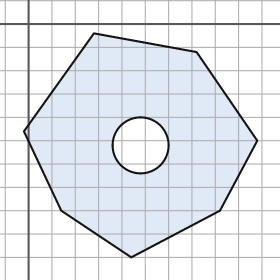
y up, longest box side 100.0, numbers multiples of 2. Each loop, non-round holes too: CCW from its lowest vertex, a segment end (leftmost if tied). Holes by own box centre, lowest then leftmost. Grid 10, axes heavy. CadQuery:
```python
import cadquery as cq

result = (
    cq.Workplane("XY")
    .moveTo(44.0, -100.0)
    .lineTo(82.0, -80.0)
    .lineTo(98.0, -50.0)
    .lineTo(72.0, -12.0)
    .lineTo(28.0, -4.0)
    .lineTo(-2.0, -46.0)
    .lineTo(14.0, -80.0)
    .close()
    .moveTo(48.0, -52.0)
    .circle(12.0)
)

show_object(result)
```